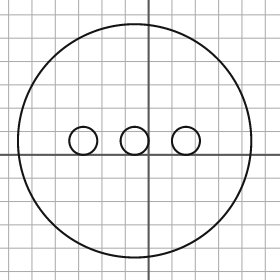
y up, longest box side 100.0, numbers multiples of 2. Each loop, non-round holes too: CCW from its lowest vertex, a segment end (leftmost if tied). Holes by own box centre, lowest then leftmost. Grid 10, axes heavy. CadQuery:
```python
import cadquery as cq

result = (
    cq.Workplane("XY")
    .moveTo(-6.0, 6.0)
    .circle(50.0)
    .moveTo(-28.0, 6.0)
    .circle(6.0)
    .moveTo(-6.0, 6.0)
    .circle(6.0)
    .moveTo(16.0, 6.0)
    .circle(6.0)
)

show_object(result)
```